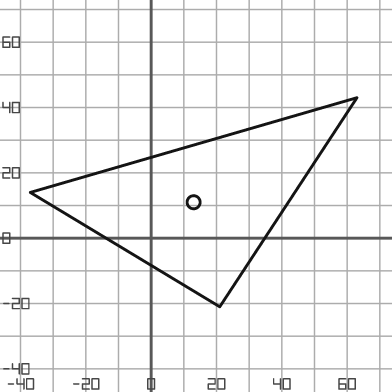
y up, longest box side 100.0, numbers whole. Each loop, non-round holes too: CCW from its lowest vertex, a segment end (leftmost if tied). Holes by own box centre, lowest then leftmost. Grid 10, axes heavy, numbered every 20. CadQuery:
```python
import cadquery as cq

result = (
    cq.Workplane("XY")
    .moveTo(21.0, -21.0)
    .lineTo(63.0, 43.0)
    .lineTo(-37.0, 14.0)
    .close()
    .moveTo(13.0, 11.0)
    .circle(2.0)
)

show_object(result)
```